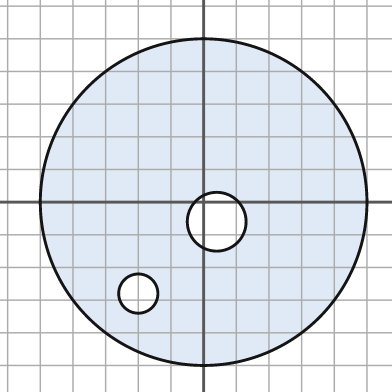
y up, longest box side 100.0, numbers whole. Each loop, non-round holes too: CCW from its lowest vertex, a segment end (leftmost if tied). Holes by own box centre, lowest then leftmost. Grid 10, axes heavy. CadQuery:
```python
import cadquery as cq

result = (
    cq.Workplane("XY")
    .moveTo(0.0, 0.0)
    .circle(50.0)
    .moveTo(-20.0, -28.0)
    .circle(6.0)
    .moveTo(4.0, -6.0)
    .circle(9.0)
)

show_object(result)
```